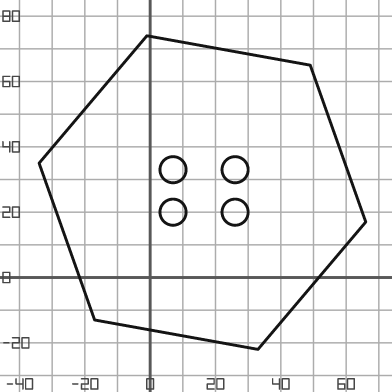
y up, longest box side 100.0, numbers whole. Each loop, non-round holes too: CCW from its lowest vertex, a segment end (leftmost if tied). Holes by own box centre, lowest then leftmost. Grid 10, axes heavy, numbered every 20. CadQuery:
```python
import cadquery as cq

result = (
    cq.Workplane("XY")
    .moveTo(33.0, -22.0)
    .lineTo(66.0, 17.0)
    .lineTo(49.0, 65.0)
    .lineTo(-1.0, 74.0)
    .lineTo(-34.0, 35.0)
    .lineTo(-17.0, -13.0)
    .close()
    .moveTo(7.0, 20.0)
    .circle(4.0)
    .moveTo(26.0, 20.0)
    .circle(4.0)
    .moveTo(7.0, 33.0)
    .circle(4.0)
    .moveTo(26.0, 33.0)
    .circle(4.0)
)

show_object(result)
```